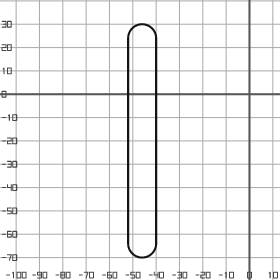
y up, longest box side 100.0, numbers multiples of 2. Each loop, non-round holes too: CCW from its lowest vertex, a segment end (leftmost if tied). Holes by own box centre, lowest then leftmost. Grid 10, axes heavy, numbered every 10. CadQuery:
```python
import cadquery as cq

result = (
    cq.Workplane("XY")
    .moveTo(-52.0, -64.0)
    .threePointArc((-46.0, -70.0), (-40.0, -64.0))
    .lineTo(-40.0, 24.0)
    .threePointArc((-46.0, 30.0), (-52.0, 24.0))
    .close()
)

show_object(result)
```